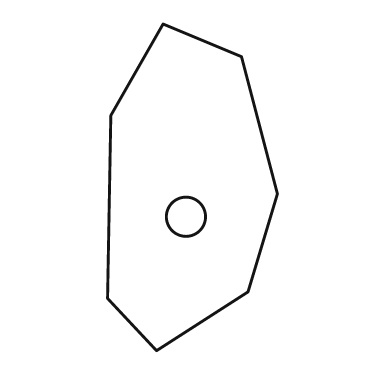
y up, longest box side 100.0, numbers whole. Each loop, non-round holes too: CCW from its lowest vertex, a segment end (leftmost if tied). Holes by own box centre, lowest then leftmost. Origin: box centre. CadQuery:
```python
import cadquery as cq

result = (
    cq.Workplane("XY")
    .moveTo(-11.0, -50.0)
    .lineTo(17.0, -32.0)
    .lineTo(26.0, -2.0)
    .lineTo(15.0, 40.0)
    .lineTo(-9.0, 50.0)
    .lineTo(-25.0, 22.0)
    .lineTo(-26.0, -34.0)
    .close()
    .moveTo(-2.0, -9.0)
    .circle(6.0)
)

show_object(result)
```